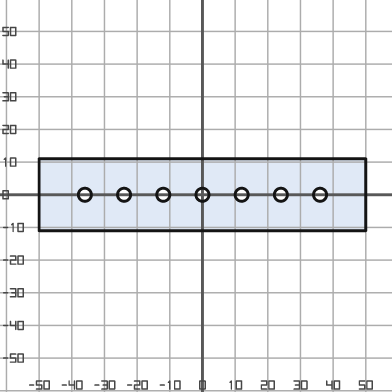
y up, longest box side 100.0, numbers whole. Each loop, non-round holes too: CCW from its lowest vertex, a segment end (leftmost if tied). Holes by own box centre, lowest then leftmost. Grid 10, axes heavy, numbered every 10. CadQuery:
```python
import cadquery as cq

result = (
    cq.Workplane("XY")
    .moveTo(-50.0, -11.0)
    .lineTo(50.0, -11.0)
    .lineTo(50.0, 11.0)
    .lineTo(-50.0, 11.0)
    .close()
    .moveTo(-36.0, 0.0)
    .circle(2.0)
    .moveTo(-24.0, 0.0)
    .circle(2.0)
    .moveTo(-12.0, 0.0)
    .circle(2.0)
    .moveTo(0.0, 0.0)
    .circle(2.0)
    .moveTo(12.0, 0.0)
    .circle(2.0)
    .moveTo(24.0, 0.0)
    .circle(2.0)
    .moveTo(36.0, 0.0)
    .circle(2.0)
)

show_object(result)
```